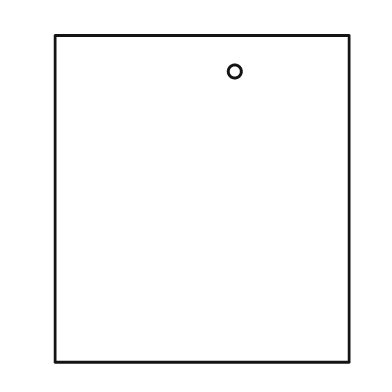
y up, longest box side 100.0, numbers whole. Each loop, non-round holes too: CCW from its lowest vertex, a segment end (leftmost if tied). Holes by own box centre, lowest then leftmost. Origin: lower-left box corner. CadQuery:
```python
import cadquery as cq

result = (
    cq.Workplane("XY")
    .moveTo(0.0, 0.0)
    .lineTo(90.0, 0.0)
    .lineTo(90.0, 100.0)
    .lineTo(0.0, 100.0)
    .close()
    .moveTo(55.0, 89.0)
    .circle(2.0)
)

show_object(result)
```